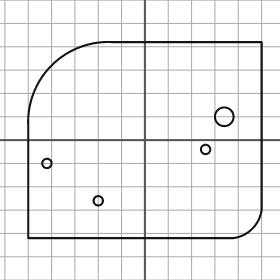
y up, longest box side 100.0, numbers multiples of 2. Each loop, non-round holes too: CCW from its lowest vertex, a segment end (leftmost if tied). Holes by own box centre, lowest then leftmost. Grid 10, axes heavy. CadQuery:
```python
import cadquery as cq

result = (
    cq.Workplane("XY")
    .moveTo(-50.0, -42.0)
    .lineTo(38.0, -42.0)
    .threePointArc((46.0, -38.0), (50.0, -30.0))
    .lineTo(50.0, 42.0)
    .lineTo(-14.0, 42.0)
    .threePointArc((-40.0, 32.0), (-50.0, 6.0))
    .close()
    .moveTo(-20.0, -26.0)
    .circle(2.0)
    .moveTo(-42.0, -10.0)
    .circle(2.0)
    .moveTo(26.0, -4.0)
    .circle(2.0)
    .moveTo(34.0, 10.0)
    .circle(4.0)
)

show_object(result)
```